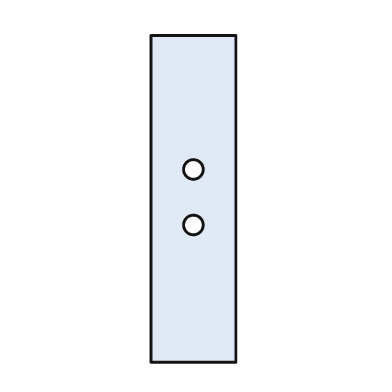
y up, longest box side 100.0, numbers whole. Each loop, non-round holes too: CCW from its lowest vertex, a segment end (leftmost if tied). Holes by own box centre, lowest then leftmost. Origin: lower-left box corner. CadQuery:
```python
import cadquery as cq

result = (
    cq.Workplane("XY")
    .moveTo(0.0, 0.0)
    .lineTo(26.0, 0.0)
    .lineTo(26.0, 100.0)
    .lineTo(0.0, 100.0)
    .close()
    .moveTo(13.0, 42.0)
    .circle(3.0)
    .moveTo(13.0, 59.0)
    .circle(3.0)
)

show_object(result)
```